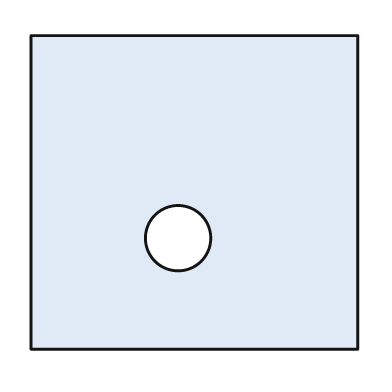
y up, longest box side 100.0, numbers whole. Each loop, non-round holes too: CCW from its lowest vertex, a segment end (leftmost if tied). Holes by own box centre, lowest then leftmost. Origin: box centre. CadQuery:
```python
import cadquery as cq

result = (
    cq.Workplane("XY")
    .moveTo(-50.0, -48.0)
    .lineTo(50.0, -48.0)
    .lineTo(50.0, 48.0)
    .lineTo(-50.0, 48.0)
    .close()
    .moveTo(-5.0, -14.0)
    .circle(10.0)
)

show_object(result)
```